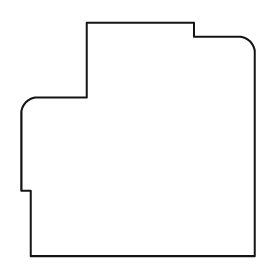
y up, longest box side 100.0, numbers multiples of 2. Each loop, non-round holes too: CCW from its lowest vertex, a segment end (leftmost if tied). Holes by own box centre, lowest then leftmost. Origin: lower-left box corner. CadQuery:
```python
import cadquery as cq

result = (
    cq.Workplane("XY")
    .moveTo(4.0, 0.0)
    .lineTo(100.0, 0.0)
    .lineTo(100.0, 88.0)
    .threePointArc((98.0, 92.0), (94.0, 94.0))
    .lineTo(74.0, 94.0)
    .lineTo(74.0, 100.0)
    .lineTo(28.0, 100.0)
    .lineTo(28.0, 68.0)
    .lineTo(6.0, 68.0)
    .threePointArc((2.0, 66.0), (0.0, 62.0))
    .lineTo(0.0, 28.0)
    .lineTo(4.0, 28.0)
    .close()
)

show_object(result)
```